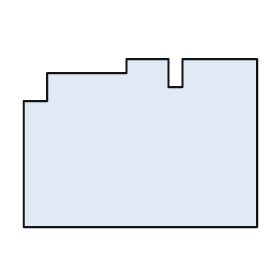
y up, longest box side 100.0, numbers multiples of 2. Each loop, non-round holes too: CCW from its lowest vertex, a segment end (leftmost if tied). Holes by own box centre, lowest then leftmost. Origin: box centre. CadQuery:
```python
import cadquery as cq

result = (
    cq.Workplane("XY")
    .moveTo(-50.0, -36.0)
    .lineTo(50.0, -36.0)
    .lineTo(50.0, 36.0)
    .lineTo(18.0, 36.0)
    .lineTo(18.0, 24.0)
    .lineTo(12.0, 24.0)
    .lineTo(12.0, 36.0)
    .lineTo(-6.0, 36.0)
    .lineTo(-6.0, 30.0)
    .lineTo(-40.0, 30.0)
    .lineTo(-40.0, 18.0)
    .lineTo(-50.0, 18.0)
    .close()
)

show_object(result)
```